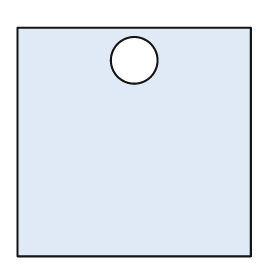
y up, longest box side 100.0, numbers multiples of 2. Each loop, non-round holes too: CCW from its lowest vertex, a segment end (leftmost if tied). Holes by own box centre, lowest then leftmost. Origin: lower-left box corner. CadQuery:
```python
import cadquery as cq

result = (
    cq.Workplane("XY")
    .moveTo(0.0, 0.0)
    .lineTo(100.0, 0.0)
    .lineTo(100.0, 98.0)
    .lineTo(0.0, 98.0)
    .close()
    .moveTo(50.0, 84.0)
    .circle(10.0)
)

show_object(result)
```